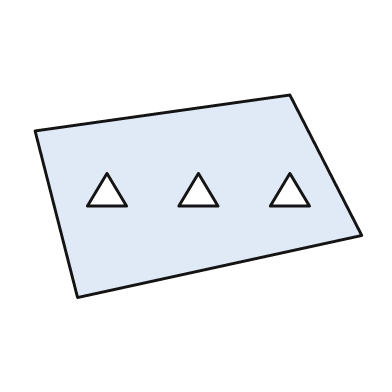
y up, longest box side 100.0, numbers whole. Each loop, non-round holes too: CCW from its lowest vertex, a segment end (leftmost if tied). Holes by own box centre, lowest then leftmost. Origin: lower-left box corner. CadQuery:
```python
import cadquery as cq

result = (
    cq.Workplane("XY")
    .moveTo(13.0, 0.0)
    .lineTo(100.0, 19.0)
    .lineTo(78.0, 62.0)
    .lineTo(0.0, 51.0)
    .close()
    .moveTo(16.0, 28.0)
    .lineTo(28.0, 28.0)
    .lineTo(22.0, 38.0)
    .close()
    .moveTo(44.0, 28.0)
    .lineTo(56.0, 28.0)
    .lineTo(50.0, 38.0)
    .close()
    .moveTo(72.0, 28.0)
    .lineTo(84.0, 28.0)
    .lineTo(78.0, 38.0)
    .close()
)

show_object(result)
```